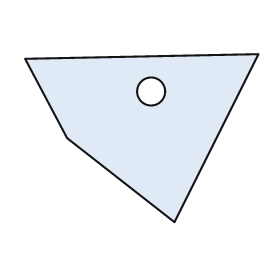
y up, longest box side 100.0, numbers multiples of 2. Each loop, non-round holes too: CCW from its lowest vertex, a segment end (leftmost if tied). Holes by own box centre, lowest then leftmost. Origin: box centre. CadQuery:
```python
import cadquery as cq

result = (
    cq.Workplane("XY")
    .moveTo(14.0, -36.0)
    .lineTo(50.0, 36.0)
    .lineTo(-50.0, 34.0)
    .lineTo(-32.0, 0.0)
    .close()
    .moveTo(4.0, 20.0)
    .circle(6.0)
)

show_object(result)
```